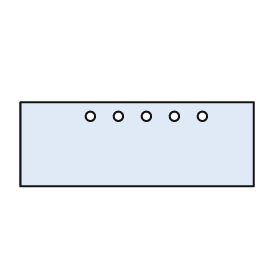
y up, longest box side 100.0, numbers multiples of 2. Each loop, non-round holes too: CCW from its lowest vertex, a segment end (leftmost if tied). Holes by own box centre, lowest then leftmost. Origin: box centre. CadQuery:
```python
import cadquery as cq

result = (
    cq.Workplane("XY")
    .moveTo(-50.0, -18.0)
    .lineTo(50.0, -18.0)
    .lineTo(50.0, 18.0)
    .lineTo(-50.0, 18.0)
    .close()
    .moveTo(-20.0, 12.0)
    .circle(2.0)
    .moveTo(-8.0, 12.0)
    .circle(2.0)
    .moveTo(4.0, 12.0)
    .circle(2.0)
    .moveTo(16.0, 12.0)
    .circle(2.0)
    .moveTo(28.0, 12.0)
    .circle(2.0)
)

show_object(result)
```